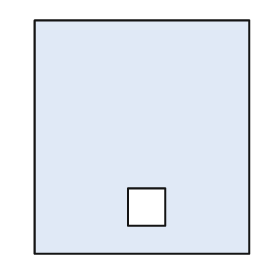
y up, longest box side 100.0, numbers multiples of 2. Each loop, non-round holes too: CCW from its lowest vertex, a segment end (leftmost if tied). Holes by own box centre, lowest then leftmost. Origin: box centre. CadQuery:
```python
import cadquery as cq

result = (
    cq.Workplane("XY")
    .moveTo(-46.0, -50.0)
    .lineTo(46.0, -50.0)
    .lineTo(46.0, 50.0)
    .lineTo(-46.0, 50.0)
    .close()
    .moveTo(-6.0, -38.0)
    .lineTo(10.0, -38.0)
    .lineTo(10.0, -22.0)
    .lineTo(-6.0, -22.0)
    .close()
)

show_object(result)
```